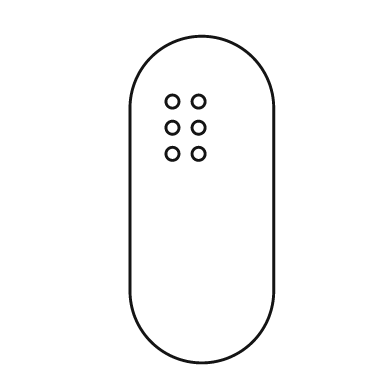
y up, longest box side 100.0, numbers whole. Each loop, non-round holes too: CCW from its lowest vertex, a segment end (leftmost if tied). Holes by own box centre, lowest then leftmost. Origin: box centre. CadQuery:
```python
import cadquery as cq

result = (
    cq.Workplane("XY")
    .moveTo(-22.0, -28.0)
    .threePointArc((0.0, -50.0), (22.0, -28.0))
    .lineTo(22.0, 28.0)
    .threePointArc((0.0, 50.0), (-22.0, 28.0))
    .close()
    .moveTo(-9.0, 14.0)
    .circle(2.0)
    .moveTo(-1.0, 14.0)
    .circle(2.0)
    .moveTo(-9.0, 22.0)
    .circle(2.0)
    .moveTo(-1.0, 22.0)
    .circle(2.0)
    .moveTo(-9.0, 30.0)
    .circle(2.0)
    .moveTo(-1.0, 30.0)
    .circle(2.0)
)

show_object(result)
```